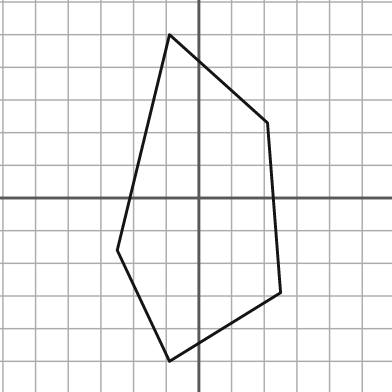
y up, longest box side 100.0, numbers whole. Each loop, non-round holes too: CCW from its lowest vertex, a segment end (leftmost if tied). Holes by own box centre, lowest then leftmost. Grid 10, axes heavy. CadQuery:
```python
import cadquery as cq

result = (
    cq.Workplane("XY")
    .moveTo(-9.0, -50.0)
    .lineTo(25.0, -29.0)
    .lineTo(21.0, 23.0)
    .lineTo(-9.0, 50.0)
    .lineTo(-25.0, -16.0)
    .close()
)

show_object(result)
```